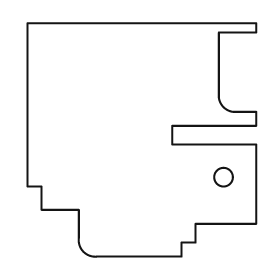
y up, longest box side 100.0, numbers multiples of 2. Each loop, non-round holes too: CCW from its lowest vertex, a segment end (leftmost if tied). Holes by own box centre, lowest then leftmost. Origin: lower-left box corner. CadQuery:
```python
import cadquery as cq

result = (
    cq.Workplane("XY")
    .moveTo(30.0, 0.0)
    .lineTo(66.0, 0.0)
    .lineTo(66.0, 6.0)
    .lineTo(72.0, 6.0)
    .lineTo(72.0, 14.0)
    .lineTo(98.0, 14.0)
    .lineTo(98.0, 48.0)
    .lineTo(62.0, 48.0)
    .lineTo(62.0, 56.0)
    .lineTo(98.0, 56.0)
    .lineTo(98.0, 62.0)
    .lineTo(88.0, 62.0)
    .threePointArc((84.0, 64.0), (82.0, 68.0))
    .lineTo(82.0, 96.0)
    .lineTo(98.0, 96.0)
    .lineTo(98.0, 100.0)
    .lineTo(0.0, 100.0)
    .lineTo(0.0, 30.0)
    .lineTo(6.0, 30.0)
    .lineTo(6.0, 20.0)
    .lineTo(22.0, 20.0)
    .lineTo(22.0, 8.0)
    .threePointArc((24.0, 2.0), (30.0, 0.0))
    .close()
    .moveTo(84.0, 34.0)
    .circle(4.0)
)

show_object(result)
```